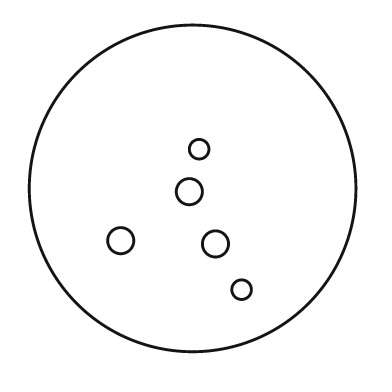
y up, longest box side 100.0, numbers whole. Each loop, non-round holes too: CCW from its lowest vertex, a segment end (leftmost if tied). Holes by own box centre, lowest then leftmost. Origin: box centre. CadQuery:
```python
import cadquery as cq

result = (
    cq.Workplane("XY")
    .moveTo(0.0, 0.0)
    .circle(50.0)
    .moveTo(15.0, -31.0)
    .circle(3.0)
    .moveTo(7.0, -17.0)
    .circle(4.0)
    .moveTo(-22.0, -16.0)
    .circle(4.0)
    .moveTo(-1.0, -1.0)
    .circle(4.0)
    .moveTo(2.0, 12.0)
    .circle(3.0)
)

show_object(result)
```